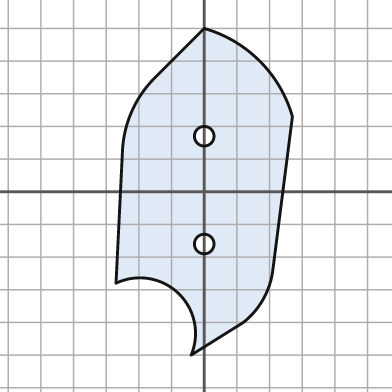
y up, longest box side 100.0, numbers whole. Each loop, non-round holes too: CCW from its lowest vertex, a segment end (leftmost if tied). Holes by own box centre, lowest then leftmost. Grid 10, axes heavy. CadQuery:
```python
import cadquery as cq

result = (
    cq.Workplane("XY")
    .moveTo(-4.0, -50.0)
    .lineTo(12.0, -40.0)
    .threePointArc((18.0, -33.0), (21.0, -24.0))
    .lineTo(27.0, 23.0)
    .threePointArc((17.0, 40.0), (0.0, 50.0))
    .lineTo(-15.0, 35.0)
    .threePointArc((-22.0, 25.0), (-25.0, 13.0))
    .lineTo(-27.0, -28.0)
    .threePointArc((-8.0, -31.0), (-4.0, -50.0))
    .close()
    .moveTo(0.0, -16.0)
    .circle(3.0)
    .moveTo(0.0, 17.0)
    .circle(3.0)
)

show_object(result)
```